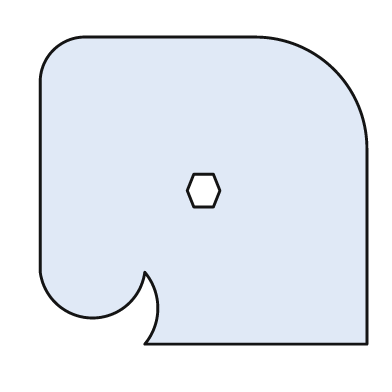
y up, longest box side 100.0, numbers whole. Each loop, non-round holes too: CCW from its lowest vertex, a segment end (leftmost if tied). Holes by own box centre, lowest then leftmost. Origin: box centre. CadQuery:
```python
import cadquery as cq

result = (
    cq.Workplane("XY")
    .moveTo(-18.0, -47.0)
    .lineTo(50.0, -47.0)
    .lineTo(50.0, 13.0)
    .threePointArc((40.0, 37.0), (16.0, 47.0))
    .lineTo(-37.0, 47.0)
    .threePointArc((-46.0, 43.0), (-50.0, 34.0))
    .lineTo(-50.0, -25.0)
    .threePointArc((-34.0, -39.0), (-18.0, -25.0))
    .threePointArc((-14.0, -36.0), (-18.0, -47.0))
    .close()
    .moveTo(-3.0, -5.0)
    .lineTo(3.0, -5.0)
    .lineTo(5.0, 0.0)
    .lineTo(3.0, 5.0)
    .lineTo(-3.0, 5.0)
    .lineTo(-5.0, 0.0)
    .close()
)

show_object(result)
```